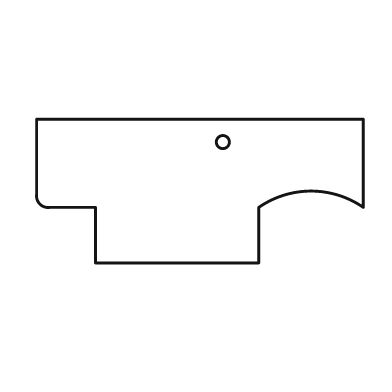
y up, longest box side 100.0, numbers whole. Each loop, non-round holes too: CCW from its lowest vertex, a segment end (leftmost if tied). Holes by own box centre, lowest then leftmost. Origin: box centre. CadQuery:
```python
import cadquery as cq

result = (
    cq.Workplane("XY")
    .moveTo(-32.0, -22.0)
    .lineTo(18.0, -22.0)
    .lineTo(18.0, -5.0)
    .threePointArc((34.0, 0.0), (50.0, -5.0))
    .lineTo(50.0, 22.0)
    .lineTo(-50.0, 22.0)
    .lineTo(-50.0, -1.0)
    .threePointArc((-49.0, -4.0), (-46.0, -5.0))
    .lineTo(-32.0, -5.0)
    .close()
    .moveTo(7.0, 15.0)
    .circle(2.0)
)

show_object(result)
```